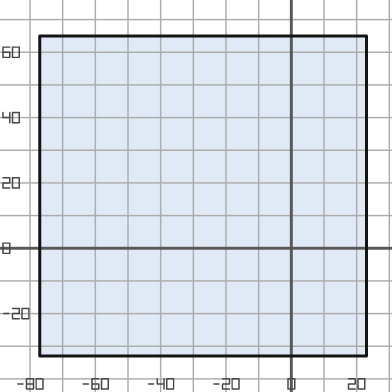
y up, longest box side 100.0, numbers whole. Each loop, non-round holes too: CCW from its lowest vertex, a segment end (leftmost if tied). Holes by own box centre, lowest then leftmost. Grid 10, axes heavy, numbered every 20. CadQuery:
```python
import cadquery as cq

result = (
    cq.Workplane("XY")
    .moveTo(-77.0, -33.0)
    .lineTo(23.0, -33.0)
    .lineTo(23.0, 65.0)
    .lineTo(-77.0, 65.0)
    .close()
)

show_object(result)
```